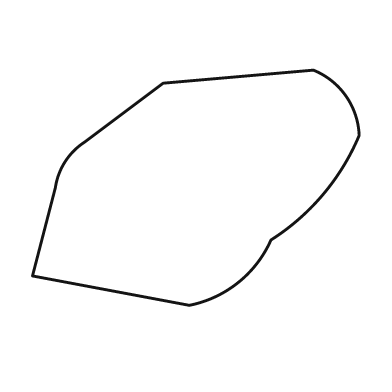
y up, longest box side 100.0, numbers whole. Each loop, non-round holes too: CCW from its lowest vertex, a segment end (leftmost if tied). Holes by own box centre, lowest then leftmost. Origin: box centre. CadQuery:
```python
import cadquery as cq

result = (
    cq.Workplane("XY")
    .moveTo(-2.0, -36.0)
    .threePointArc((13.0, -29.0), (23.0, -16.0))
    .threePointArc((39.0, -2.0), (50.0, 16.0))
    .threePointArc((46.0, 28.0), (36.0, 36.0))
    .lineTo(-10.0, 32.0)
    .lineTo(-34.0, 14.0)
    .threePointArc((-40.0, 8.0), (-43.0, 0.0))
    .lineTo(-50.0, -27.0)
    .close()
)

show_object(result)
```